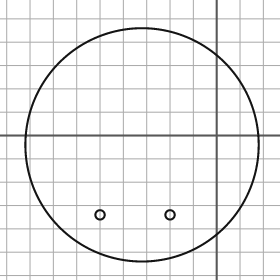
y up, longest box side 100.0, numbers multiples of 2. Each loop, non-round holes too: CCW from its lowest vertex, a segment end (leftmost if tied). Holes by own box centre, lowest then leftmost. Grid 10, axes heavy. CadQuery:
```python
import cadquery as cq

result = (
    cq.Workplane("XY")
    .moveTo(-32.0, -4.0)
    .circle(50.0)
    .moveTo(-50.0, -34.0)
    .circle(2.0)
    .moveTo(-20.0, -34.0)
    .circle(2.0)
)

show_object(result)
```